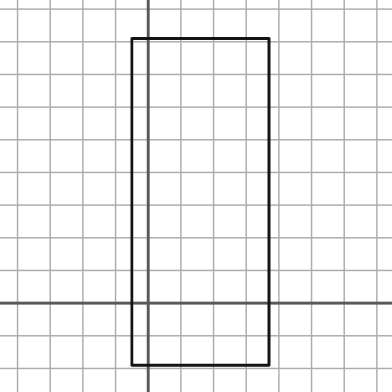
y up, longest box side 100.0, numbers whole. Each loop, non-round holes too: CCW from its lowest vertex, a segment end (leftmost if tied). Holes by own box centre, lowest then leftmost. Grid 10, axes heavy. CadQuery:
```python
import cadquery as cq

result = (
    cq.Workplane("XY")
    .moveTo(-5.0, -19.0)
    .lineTo(37.0, -19.0)
    .lineTo(37.0, 81.0)
    .lineTo(-5.0, 81.0)
    .close()
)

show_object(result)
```